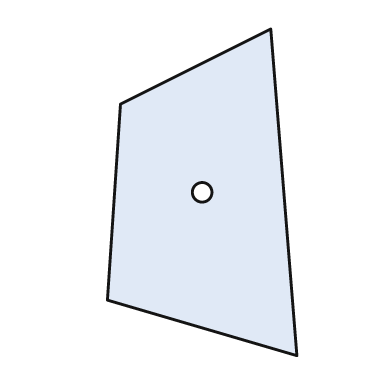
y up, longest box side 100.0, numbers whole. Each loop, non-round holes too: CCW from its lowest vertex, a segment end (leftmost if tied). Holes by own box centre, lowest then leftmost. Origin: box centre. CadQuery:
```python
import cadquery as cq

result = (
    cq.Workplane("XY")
    .moveTo(29.0, -50.0)
    .lineTo(21.0, 50.0)
    .lineTo(-25.0, 27.0)
    .lineTo(-29.0, -33.0)
    .close()
    .moveTo(0.0, 0.0)
    .circle(3.0)
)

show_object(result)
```